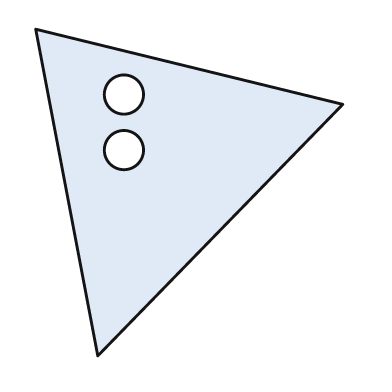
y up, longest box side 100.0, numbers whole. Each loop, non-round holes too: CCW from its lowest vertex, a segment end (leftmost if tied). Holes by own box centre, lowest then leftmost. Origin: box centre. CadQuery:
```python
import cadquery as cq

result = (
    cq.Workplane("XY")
    .moveTo(-28.0, -50.0)
    .lineTo(47.0, 27.0)
    .lineTo(-47.0, 50.0)
    .close()
    .moveTo(-20.0, 13.0)
    .circle(6.0)
    .moveTo(-20.0, 30.0)
    .circle(6.0)
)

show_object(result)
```